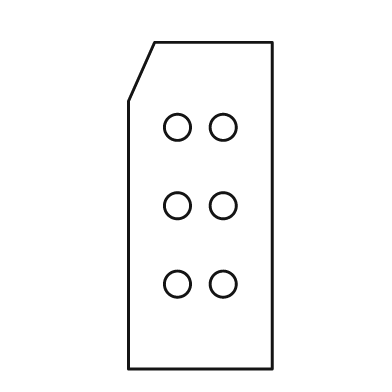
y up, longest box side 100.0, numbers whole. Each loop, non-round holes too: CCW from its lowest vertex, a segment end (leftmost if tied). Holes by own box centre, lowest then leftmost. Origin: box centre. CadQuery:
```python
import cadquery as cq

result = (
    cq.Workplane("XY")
    .moveTo(-22.0, -50.0)
    .lineTo(22.0, -50.0)
    .lineTo(22.0, 50.0)
    .lineTo(-14.0, 50.0)
    .lineTo(-22.0, 32.0)
    .close()
    .moveTo(-7.0, -24.0)
    .circle(4.0)
    .moveTo(7.0, -24.0)
    .circle(4.0)
    .moveTo(-7.0, 0.0)
    .circle(4.0)
    .moveTo(7.0, 0.0)
    .circle(4.0)
    .moveTo(-7.0, 24.0)
    .circle(4.0)
    .moveTo(7.0, 24.0)
    .circle(4.0)
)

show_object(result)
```